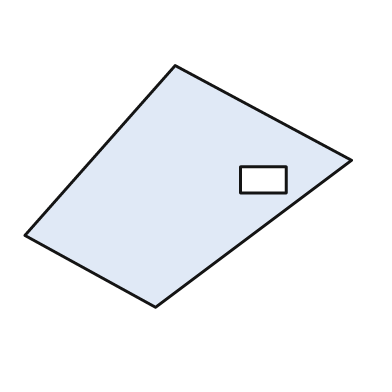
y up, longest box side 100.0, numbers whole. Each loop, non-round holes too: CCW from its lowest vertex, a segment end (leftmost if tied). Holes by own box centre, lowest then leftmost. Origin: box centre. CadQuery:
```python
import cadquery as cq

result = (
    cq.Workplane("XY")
    .moveTo(-10.0, -37.0)
    .lineTo(50.0, 8.0)
    .lineTo(-4.0, 37.0)
    .lineTo(-50.0, -15.0)
    .close()
    .moveTo(16.0, -2.0)
    .lineTo(30.0, -2.0)
    .lineTo(30.0, 6.0)
    .lineTo(16.0, 6.0)
    .close()
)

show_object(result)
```